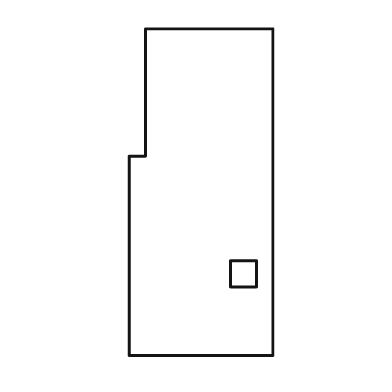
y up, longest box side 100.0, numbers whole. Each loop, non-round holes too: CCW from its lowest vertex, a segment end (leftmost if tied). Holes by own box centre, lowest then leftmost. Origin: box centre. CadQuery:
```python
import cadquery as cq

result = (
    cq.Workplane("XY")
    .moveTo(-22.0, -50.0)
    .lineTo(22.0, -50.0)
    .lineTo(22.0, 50.0)
    .lineTo(-17.0, 50.0)
    .lineTo(-17.0, 11.0)
    .lineTo(-22.0, 11.0)
    .close()
    .moveTo(9.0, -29.0)
    .lineTo(17.0, -29.0)
    .lineTo(17.0, -21.0)
    .lineTo(9.0, -21.0)
    .close()
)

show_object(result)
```